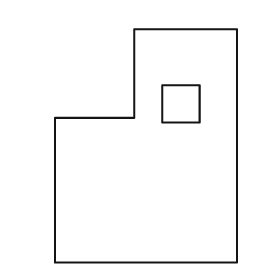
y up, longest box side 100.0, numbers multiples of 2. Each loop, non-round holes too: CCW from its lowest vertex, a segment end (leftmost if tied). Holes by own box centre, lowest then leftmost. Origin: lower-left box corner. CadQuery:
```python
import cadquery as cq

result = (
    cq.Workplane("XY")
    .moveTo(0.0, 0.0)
    .lineTo(78.0, 0.0)
    .lineTo(78.0, 100.0)
    .lineTo(34.0, 100.0)
    .lineTo(34.0, 62.0)
    .lineTo(0.0, 62.0)
    .close()
    .moveTo(46.0, 60.0)
    .lineTo(62.0, 60.0)
    .lineTo(62.0, 76.0)
    .lineTo(46.0, 76.0)
    .close()
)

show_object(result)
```